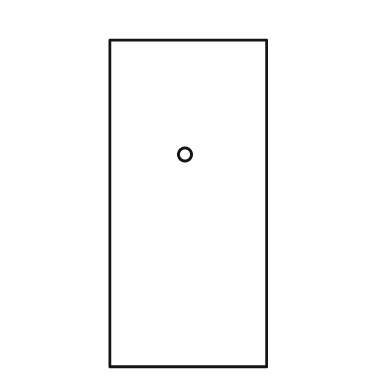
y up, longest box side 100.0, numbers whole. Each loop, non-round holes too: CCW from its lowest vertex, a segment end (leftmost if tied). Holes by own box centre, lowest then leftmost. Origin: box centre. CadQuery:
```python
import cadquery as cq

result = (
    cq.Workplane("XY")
    .moveTo(-24.0, -50.0)
    .lineTo(24.0, -50.0)
    .lineTo(24.0, 50.0)
    .lineTo(-24.0, 50.0)
    .close()
    .moveTo(-1.0, 15.0)
    .circle(2.0)
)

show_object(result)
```